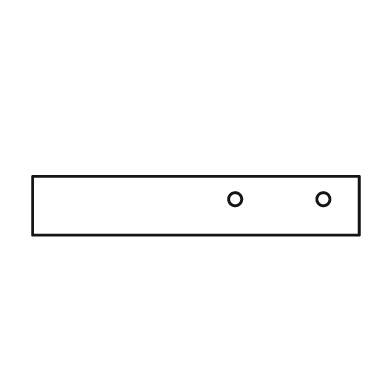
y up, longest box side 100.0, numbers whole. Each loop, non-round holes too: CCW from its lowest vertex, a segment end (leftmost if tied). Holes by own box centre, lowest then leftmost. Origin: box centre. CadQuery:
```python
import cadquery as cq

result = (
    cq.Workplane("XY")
    .moveTo(-50.0, -9.0)
    .lineTo(50.0, -9.0)
    .lineTo(50.0, 9.0)
    .lineTo(-50.0, 9.0)
    .close()
    .moveTo(12.0, 2.0)
    .circle(2.0)
    .moveTo(39.0, 2.0)
    .circle(2.0)
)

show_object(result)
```